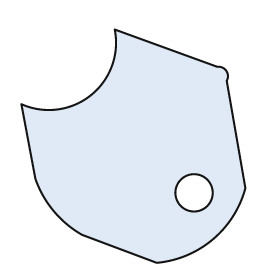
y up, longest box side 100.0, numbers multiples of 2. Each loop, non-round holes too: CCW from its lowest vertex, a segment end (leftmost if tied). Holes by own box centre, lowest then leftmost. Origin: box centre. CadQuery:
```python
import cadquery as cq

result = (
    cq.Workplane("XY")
    .moveTo(10.0, -50.0)
    .threePointArc((34.0, -40.0), (48.0, -18.0))
    .lineTo(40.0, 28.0)
    .threePointArc((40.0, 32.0), (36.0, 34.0))
    .lineTo(-8.0, 50.0)
    .threePointArc((-18.0, 22.0), (-48.0, 18.0))
    .lineTo(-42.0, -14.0)
    .threePointArc((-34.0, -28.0), (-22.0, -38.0))
    .close()
    .moveTo(26.0, -20.0)
    .circle(8.0)
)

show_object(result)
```